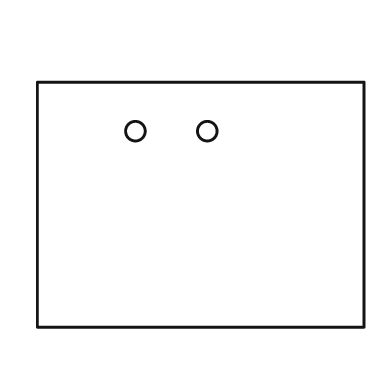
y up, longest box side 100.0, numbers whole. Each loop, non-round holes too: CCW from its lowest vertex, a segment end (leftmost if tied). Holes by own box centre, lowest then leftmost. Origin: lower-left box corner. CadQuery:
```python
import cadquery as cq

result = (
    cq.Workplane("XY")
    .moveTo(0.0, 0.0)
    .lineTo(100.0, 0.0)
    .lineTo(100.0, 75.0)
    .lineTo(0.0, 75.0)
    .close()
    .moveTo(30.0, 60.0)
    .circle(3.0)
    .moveTo(52.0, 60.0)
    .circle(3.0)
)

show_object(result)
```